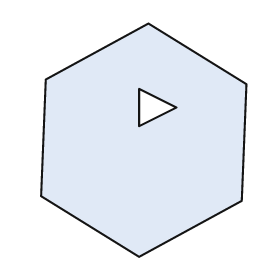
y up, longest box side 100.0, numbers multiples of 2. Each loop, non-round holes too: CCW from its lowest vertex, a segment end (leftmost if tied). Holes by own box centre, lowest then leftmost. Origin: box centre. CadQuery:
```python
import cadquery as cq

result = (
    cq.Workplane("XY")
    .moveTo(-2.0, -50.0)
    .lineTo(42.0, -26.0)
    .lineTo(44.0, 24.0)
    .lineTo(2.0, 50.0)
    .lineTo(-42.0, 26.0)
    .lineTo(-44.0, -24.0)
    .close()
    .moveTo(-2.0, 6.0)
    .lineTo(14.0, 14.0)
    .lineTo(-2.0, 22.0)
    .close()
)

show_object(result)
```